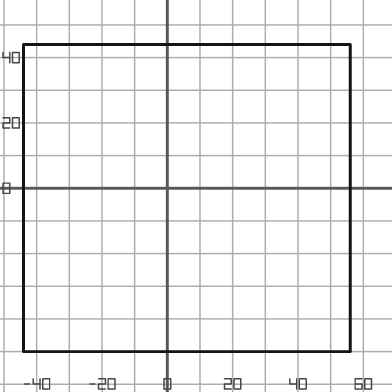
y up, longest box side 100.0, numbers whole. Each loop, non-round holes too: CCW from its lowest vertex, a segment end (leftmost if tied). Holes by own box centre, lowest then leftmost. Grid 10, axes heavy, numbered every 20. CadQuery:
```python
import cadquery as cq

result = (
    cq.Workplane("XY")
    .moveTo(-44.0, -50.0)
    .lineTo(56.0, -50.0)
    .lineTo(56.0, 44.0)
    .lineTo(-44.0, 44.0)
    .close()
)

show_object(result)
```